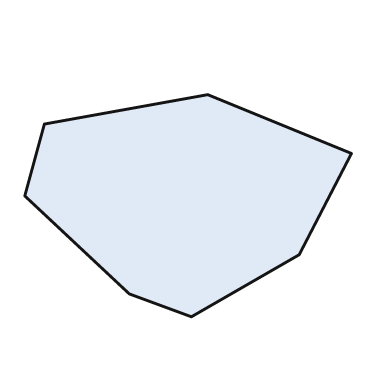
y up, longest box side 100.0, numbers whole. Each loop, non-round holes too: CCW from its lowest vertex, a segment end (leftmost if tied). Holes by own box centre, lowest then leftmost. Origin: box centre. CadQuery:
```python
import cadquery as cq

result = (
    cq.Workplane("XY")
    .moveTo(1.0, -34.0)
    .lineTo(34.0, -15.0)
    .lineTo(50.0, 16.0)
    .lineTo(6.0, 34.0)
    .lineTo(-44.0, 25.0)
    .lineTo(-50.0, 3.0)
    .lineTo(-18.0, -27.0)
    .close()
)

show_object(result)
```